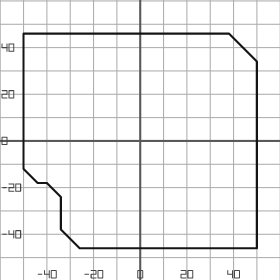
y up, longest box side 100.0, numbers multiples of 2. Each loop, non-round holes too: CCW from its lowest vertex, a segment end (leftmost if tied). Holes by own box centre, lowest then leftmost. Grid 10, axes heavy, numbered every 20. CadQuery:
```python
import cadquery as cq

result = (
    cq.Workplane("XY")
    .moveTo(-26.0, -46.0)
    .lineTo(50.0, -46.0)
    .lineTo(50.0, 34.0)
    .lineTo(38.0, 46.0)
    .lineTo(-50.0, 46.0)
    .lineTo(-50.0, -12.0)
    .lineTo(-44.0, -18.0)
    .lineTo(-40.0, -18.0)
    .lineTo(-34.0, -24.0)
    .lineTo(-34.0, -38.0)
    .close()
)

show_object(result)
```